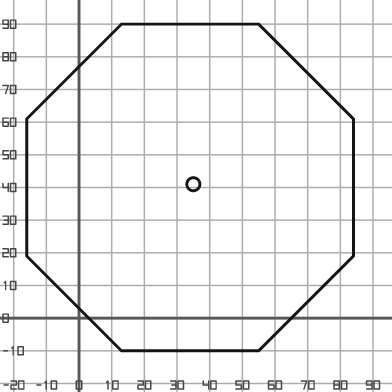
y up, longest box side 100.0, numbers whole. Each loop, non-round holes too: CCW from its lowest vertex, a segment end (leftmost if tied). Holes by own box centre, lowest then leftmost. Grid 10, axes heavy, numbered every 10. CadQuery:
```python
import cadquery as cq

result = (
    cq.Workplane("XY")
    .moveTo(13.0, -10.0)
    .lineTo(55.0, -10.0)
    .lineTo(84.0, 19.0)
    .lineTo(84.0, 61.0)
    .lineTo(55.0, 90.0)
    .lineTo(13.0, 90.0)
    .lineTo(-16.0, 61.0)
    .lineTo(-16.0, 19.0)
    .close()
    .moveTo(35.0, 41.0)
    .circle(2.0)
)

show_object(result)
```